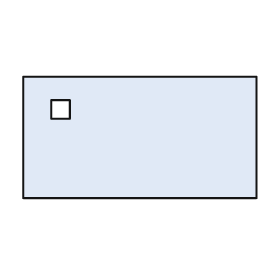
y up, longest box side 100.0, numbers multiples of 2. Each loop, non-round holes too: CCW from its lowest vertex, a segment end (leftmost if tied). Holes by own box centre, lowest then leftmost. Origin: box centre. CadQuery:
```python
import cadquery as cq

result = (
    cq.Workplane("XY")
    .moveTo(-50.0, -26.0)
    .lineTo(50.0, -26.0)
    .lineTo(50.0, 26.0)
    .lineTo(-50.0, 26.0)
    .close()
    .moveTo(-38.0, 8.0)
    .lineTo(-30.0, 8.0)
    .lineTo(-30.0, 16.0)
    .lineTo(-38.0, 16.0)
    .close()
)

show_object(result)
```